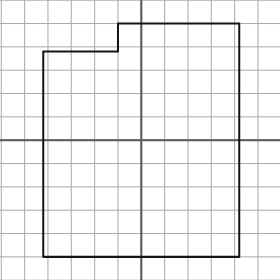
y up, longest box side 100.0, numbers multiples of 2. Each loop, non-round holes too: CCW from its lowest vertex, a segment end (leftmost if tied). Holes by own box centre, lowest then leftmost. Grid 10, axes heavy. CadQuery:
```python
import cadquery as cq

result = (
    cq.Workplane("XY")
    .moveTo(-42.0, -50.0)
    .lineTo(42.0, -50.0)
    .lineTo(42.0, 50.0)
    .lineTo(-10.0, 50.0)
    .lineTo(-10.0, 38.0)
    .lineTo(-42.0, 38.0)
    .close()
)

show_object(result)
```